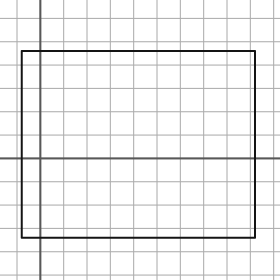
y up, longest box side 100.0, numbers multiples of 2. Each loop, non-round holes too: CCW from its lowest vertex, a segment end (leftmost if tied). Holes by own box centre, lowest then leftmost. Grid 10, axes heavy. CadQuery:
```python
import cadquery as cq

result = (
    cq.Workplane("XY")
    .moveTo(-8.0, -34.0)
    .lineTo(92.0, -34.0)
    .lineTo(92.0, 46.0)
    .lineTo(-8.0, 46.0)
    .close()
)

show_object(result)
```